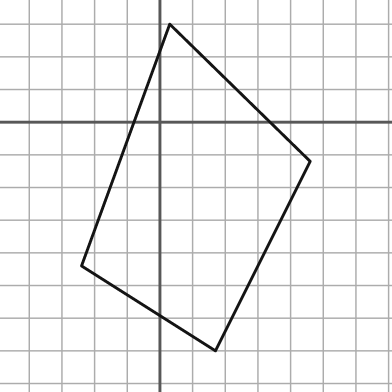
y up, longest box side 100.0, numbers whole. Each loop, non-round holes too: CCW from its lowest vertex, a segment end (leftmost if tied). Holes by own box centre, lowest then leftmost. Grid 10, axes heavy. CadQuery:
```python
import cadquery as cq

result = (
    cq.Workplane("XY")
    .moveTo(17.0, -70.0)
    .lineTo(46.0, -12.0)
    .lineTo(3.0, 30.0)
    .lineTo(-24.0, -44.0)
    .close()
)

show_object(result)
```